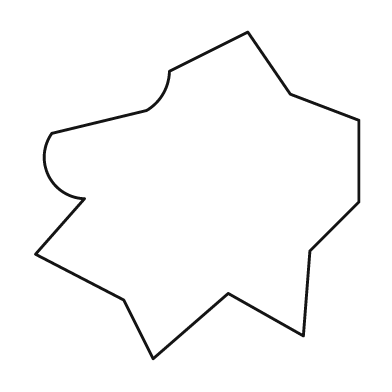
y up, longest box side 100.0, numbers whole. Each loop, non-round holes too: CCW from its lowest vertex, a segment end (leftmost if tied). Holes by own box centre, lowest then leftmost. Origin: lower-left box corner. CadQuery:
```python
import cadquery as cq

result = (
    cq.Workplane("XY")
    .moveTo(36.0, 0.0)
    .lineTo(59.0, 20.0)
    .lineTo(82.0, 7.0)
    .lineTo(84.0, 33.0)
    .lineTo(99.0, 48.0)
    .lineTo(99.0, 73.0)
    .lineTo(78.0, 81.0)
    .lineTo(65.0, 100.0)
    .lineTo(41.0, 88.0)
    .threePointArc((39.0, 81.0), (34.0, 76.0))
    .lineTo(5.0, 69.0)
    .threePointArc((4.0, 56.0), (15.0, 49.0))
    .lineTo(0.0, 32.0)
    .lineTo(27.0, 18.0)
    .close()
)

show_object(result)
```